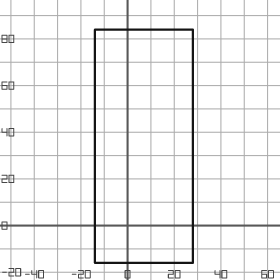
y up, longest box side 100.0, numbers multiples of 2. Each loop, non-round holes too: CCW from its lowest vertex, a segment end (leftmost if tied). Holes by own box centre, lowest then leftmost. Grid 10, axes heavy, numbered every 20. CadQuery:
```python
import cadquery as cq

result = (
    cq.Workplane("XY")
    .moveTo(-14.0, -16.0)
    .lineTo(28.0, -16.0)
    .lineTo(28.0, 84.0)
    .lineTo(-14.0, 84.0)
    .close()
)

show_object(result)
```